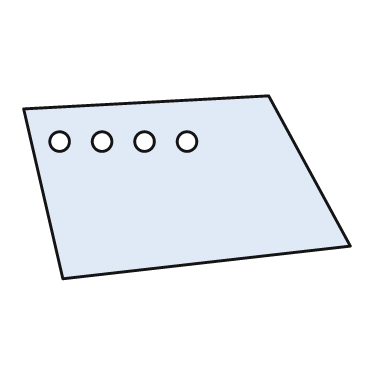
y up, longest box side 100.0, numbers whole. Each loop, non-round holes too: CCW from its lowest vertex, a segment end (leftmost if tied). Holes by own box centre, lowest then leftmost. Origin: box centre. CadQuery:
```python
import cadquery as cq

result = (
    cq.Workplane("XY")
    .moveTo(-38.0, -28.0)
    .lineTo(50.0, -18.0)
    .lineTo(25.0, 28.0)
    .lineTo(-50.0, 24.0)
    .close()
    .moveTo(-39.0, 14.0)
    .circle(3.0)
    .moveTo(-26.0, 14.0)
    .circle(3.0)
    .moveTo(-13.0, 14.0)
    .circle(3.0)
    .moveTo(0.0, 14.0)
    .circle(3.0)
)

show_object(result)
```